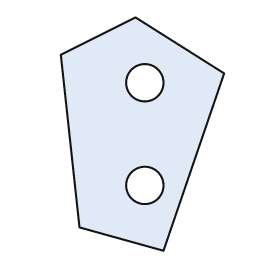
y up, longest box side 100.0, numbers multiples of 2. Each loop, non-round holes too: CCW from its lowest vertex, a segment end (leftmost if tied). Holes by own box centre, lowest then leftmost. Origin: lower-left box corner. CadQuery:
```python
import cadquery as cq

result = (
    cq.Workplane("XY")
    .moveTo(44.0, 0.0)
    .lineTo(70.0, 76.0)
    .lineTo(32.0, 100.0)
    .lineTo(0.0, 84.0)
    .lineTo(8.0, 10.0)
    .close()
    .moveTo(36.0, 28.0)
    .circle(8.0)
    .moveTo(36.0, 72.0)
    .circle(8.0)
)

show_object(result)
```